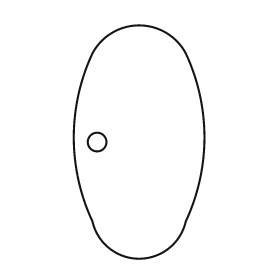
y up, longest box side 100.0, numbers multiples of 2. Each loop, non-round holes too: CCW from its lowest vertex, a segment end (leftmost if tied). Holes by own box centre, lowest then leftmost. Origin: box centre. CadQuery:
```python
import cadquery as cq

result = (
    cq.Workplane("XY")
    .moveTo(-20.0, -34.0)
    .threePointArc((0.0, -50.0), (20.0, -34.0))
    .threePointArc((28.0, 2.0), (20.0, 38.0))
    .threePointArc((0.0, 50.0), (-20.0, 38.0))
    .threePointArc((-28.0, 2.0), (-20.0, -34.0))
    .close()
    .moveTo(-18.0, 0.0)
    .circle(4.0)
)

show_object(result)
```